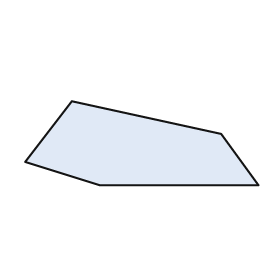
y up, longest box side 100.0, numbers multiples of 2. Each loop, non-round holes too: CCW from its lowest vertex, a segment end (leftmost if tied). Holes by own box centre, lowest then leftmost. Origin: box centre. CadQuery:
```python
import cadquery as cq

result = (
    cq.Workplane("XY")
    .moveTo(-18.0, -18.0)
    .lineTo(50.0, -18.0)
    .lineTo(34.0, 4.0)
    .lineTo(-30.0, 18.0)
    .lineTo(-50.0, -8.0)
    .close()
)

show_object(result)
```